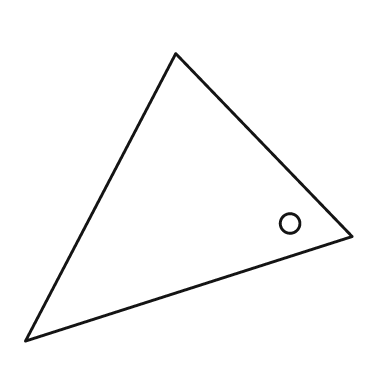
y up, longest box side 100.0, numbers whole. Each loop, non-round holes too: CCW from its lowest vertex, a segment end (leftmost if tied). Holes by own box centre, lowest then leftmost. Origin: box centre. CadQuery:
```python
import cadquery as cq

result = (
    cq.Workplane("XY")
    .moveTo(-50.0, -44.0)
    .lineTo(50.0, -12.0)
    .lineTo(-4.0, 44.0)
    .close()
    .moveTo(31.0, -8.0)
    .circle(3.0)
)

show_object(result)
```